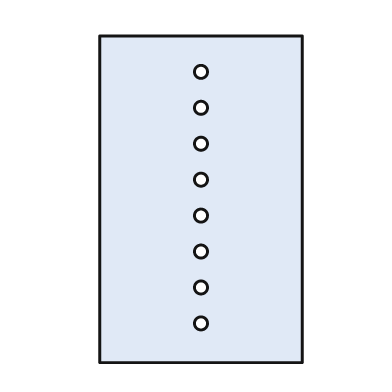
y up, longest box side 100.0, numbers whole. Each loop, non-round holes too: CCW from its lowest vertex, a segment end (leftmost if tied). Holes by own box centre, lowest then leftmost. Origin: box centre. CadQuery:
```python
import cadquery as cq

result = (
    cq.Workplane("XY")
    .moveTo(-31.0, -50.0)
    .lineTo(31.0, -50.0)
    .lineTo(31.0, 50.0)
    .lineTo(-31.0, 50.0)
    .close()
    .moveTo(0.0, -38.0)
    .circle(2.0)
    .moveTo(0.0, -27.0)
    .circle(2.0)
    .moveTo(0.0, -16.0)
    .circle(2.0)
    .moveTo(0.0, -5.0)
    .circle(2.0)
    .moveTo(0.0, 6.0)
    .circle(2.0)
    .moveTo(0.0, 17.0)
    .circle(2.0)
    .moveTo(0.0, 28.0)
    .circle(2.0)
    .moveTo(0.0, 39.0)
    .circle(2.0)
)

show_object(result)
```